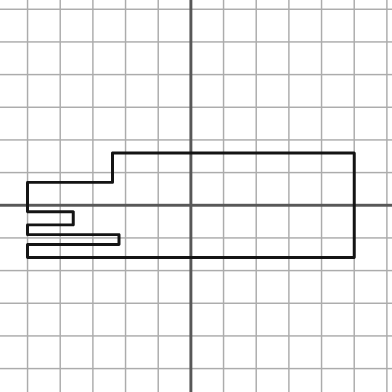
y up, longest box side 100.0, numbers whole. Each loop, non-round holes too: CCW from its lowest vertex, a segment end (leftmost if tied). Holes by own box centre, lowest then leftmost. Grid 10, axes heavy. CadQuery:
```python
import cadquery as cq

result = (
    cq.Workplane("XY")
    .moveTo(-50.0, -16.0)
    .lineTo(50.0, -16.0)
    .lineTo(50.0, 16.0)
    .lineTo(-24.0, 16.0)
    .lineTo(-24.0, 7.0)
    .lineTo(-50.0, 7.0)
    .lineTo(-50.0, -2.0)
    .lineTo(-36.0, -2.0)
    .lineTo(-36.0, -6.0)
    .lineTo(-50.0, -6.0)
    .lineTo(-50.0, -9.0)
    .lineTo(-22.0, -9.0)
    .lineTo(-22.0, -12.0)
    .lineTo(-50.0, -12.0)
    .close()
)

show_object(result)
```